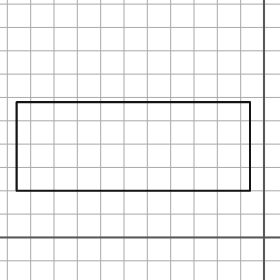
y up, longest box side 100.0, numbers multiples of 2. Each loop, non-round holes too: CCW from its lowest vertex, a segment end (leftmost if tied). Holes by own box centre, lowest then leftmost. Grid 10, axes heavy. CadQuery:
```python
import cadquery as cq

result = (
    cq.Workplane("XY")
    .moveTo(-106.0, 20.0)
    .lineTo(-6.0, 20.0)
    .lineTo(-6.0, 58.0)
    .lineTo(-106.0, 58.0)
    .close()
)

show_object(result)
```